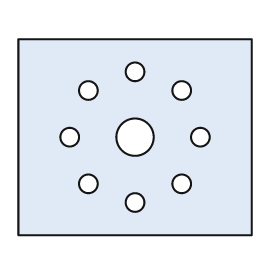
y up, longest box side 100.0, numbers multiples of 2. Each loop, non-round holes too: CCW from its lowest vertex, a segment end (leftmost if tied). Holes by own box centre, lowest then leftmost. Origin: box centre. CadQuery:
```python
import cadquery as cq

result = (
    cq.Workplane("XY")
    .moveTo(-50.0, -42.0)
    .lineTo(50.0, -42.0)
    .lineTo(50.0, 42.0)
    .lineTo(-50.0, 42.0)
    .close()
    .moveTo(0.0, -28.0)
    .circle(4.0)
    .moveTo(-20.0, -20.0)
    .circle(4.0)
    .moveTo(20.0, -20.0)
    .circle(4.0)
    .moveTo(-28.0, 0.0)
    .circle(4.0)
    .moveTo(0.0, 0.0)
    .circle(8.0)
    .moveTo(28.0, 0.0)
    .circle(4.0)
    .moveTo(-20.0, 20.0)
    .circle(4.0)
    .moveTo(20.0, 20.0)
    .circle(4.0)
    .moveTo(0.0, 28.0)
    .circle(4.0)
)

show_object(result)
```